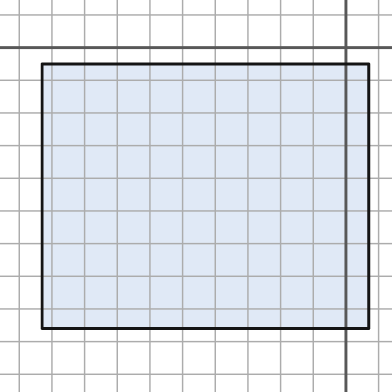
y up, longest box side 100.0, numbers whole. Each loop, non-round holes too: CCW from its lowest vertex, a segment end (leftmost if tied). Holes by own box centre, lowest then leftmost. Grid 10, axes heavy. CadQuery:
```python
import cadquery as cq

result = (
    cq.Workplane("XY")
    .moveTo(-93.0, -86.0)
    .lineTo(7.0, -86.0)
    .lineTo(7.0, -5.0)
    .lineTo(-93.0, -5.0)
    .close()
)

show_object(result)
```